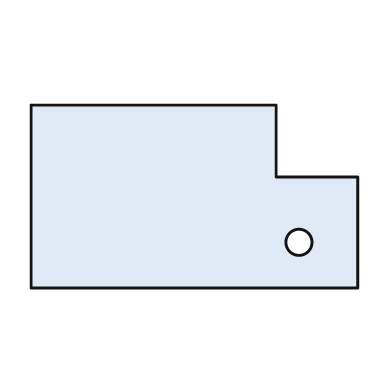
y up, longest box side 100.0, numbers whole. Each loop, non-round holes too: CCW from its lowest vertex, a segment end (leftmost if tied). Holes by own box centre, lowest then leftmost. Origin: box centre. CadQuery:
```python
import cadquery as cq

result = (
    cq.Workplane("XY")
    .moveTo(-50.0, -28.0)
    .lineTo(50.0, -28.0)
    .lineTo(50.0, 6.0)
    .lineTo(25.0, 6.0)
    .lineTo(25.0, 28.0)
    .lineTo(-50.0, 28.0)
    .close()
    .moveTo(32.0, -14.0)
    .circle(4.0)
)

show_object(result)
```